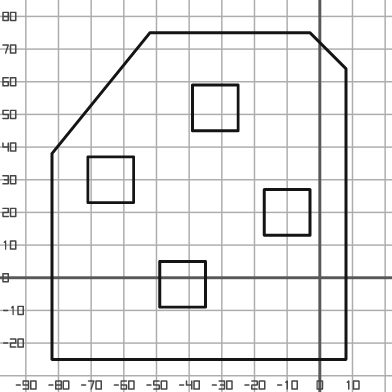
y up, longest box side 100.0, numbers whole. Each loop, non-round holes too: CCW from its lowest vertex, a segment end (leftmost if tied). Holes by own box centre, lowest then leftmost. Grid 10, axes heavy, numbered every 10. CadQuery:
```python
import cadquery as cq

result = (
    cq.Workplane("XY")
    .moveTo(-82.0, -25.0)
    .lineTo(8.0, -25.0)
    .lineTo(8.0, 64.0)
    .lineTo(-3.0, 75.0)
    .lineTo(-52.0, 75.0)
    .lineTo(-82.0, 38.0)
    .close()
    .moveTo(-49.0, -9.0)
    .lineTo(-35.0, -9.0)
    .lineTo(-35.0, 5.0)
    .lineTo(-49.0, 5.0)
    .close()
    .moveTo(-17.0, 13.0)
    .lineTo(-3.0, 13.0)
    .lineTo(-3.0, 27.0)
    .lineTo(-17.0, 27.0)
    .close()
    .moveTo(-71.0, 23.0)
    .lineTo(-57.0, 23.0)
    .lineTo(-57.0, 37.0)
    .lineTo(-71.0, 37.0)
    .close()
    .moveTo(-39.0, 45.0)
    .lineTo(-25.0, 45.0)
    .lineTo(-25.0, 59.0)
    .lineTo(-39.0, 59.0)
    .close()
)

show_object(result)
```